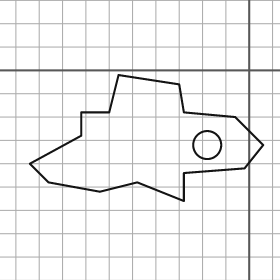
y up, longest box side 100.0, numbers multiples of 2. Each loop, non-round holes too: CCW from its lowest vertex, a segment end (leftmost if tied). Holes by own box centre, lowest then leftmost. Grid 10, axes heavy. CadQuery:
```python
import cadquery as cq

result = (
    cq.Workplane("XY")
    .moveTo(-28.0, -56.0)
    .lineTo(-28.0, -44.0)
    .lineTo(-2.0, -42.0)
    .lineTo(6.0, -32.0)
    .lineTo(-6.0, -20.0)
    .lineTo(-28.0, -18.0)
    .lineTo(-30.0, -6.0)
    .lineTo(-56.0, -2.0)
    .lineTo(-60.0, -18.0)
    .lineTo(-72.0, -18.0)
    .lineTo(-72.0, -28.0)
    .lineTo(-94.0, -40.0)
    .lineTo(-86.0, -48.0)
    .lineTo(-64.0, -52.0)
    .lineTo(-48.0, -48.0)
    .close()
    .moveTo(-18.0, -32.0)
    .circle(6.0)
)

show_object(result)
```